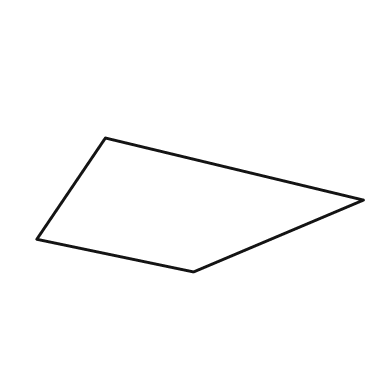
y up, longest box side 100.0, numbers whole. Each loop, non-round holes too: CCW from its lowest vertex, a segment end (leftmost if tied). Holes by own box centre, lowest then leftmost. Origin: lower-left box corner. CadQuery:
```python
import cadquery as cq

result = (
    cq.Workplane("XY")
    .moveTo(48.0, 0.0)
    .lineTo(100.0, 22.0)
    .lineTo(21.0, 41.0)
    .lineTo(0.0, 10.0)
    .close()
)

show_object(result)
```